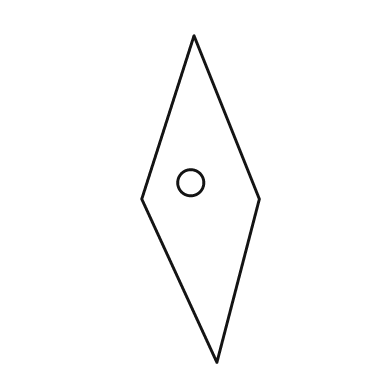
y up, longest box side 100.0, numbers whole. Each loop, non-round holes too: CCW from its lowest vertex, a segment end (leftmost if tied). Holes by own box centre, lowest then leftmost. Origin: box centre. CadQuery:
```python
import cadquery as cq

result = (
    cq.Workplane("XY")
    .moveTo(5.0, -50.0)
    .lineTo(18.0, 0.0)
    .lineTo(-2.0, 50.0)
    .lineTo(-18.0, 0.0)
    .close()
    .moveTo(-3.0, 5.0)
    .circle(4.0)
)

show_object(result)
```